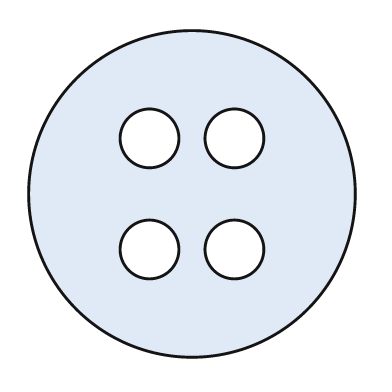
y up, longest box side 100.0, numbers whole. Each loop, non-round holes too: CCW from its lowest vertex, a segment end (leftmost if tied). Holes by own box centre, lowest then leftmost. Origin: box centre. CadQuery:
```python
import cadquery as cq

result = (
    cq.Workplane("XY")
    .moveTo(0.0, 0.0)
    .circle(50.0)
    .moveTo(-13.0, -17.0)
    .circle(9.0)
    .moveTo(13.0, -17.0)
    .circle(9.0)
    .moveTo(-13.0, 17.0)
    .circle(9.0)
    .moveTo(13.0, 17.0)
    .circle(9.0)
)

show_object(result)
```